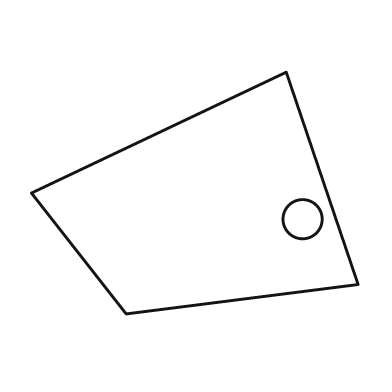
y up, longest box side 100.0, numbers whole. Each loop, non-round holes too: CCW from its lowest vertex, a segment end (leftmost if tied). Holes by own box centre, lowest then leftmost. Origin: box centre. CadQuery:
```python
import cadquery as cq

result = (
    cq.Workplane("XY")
    .moveTo(-21.0, -37.0)
    .lineTo(50.0, -28.0)
    .lineTo(28.0, 37.0)
    .lineTo(-50.0, 0.0)
    .close()
    .moveTo(33.0, -8.0)
    .circle(6.0)
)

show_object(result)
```